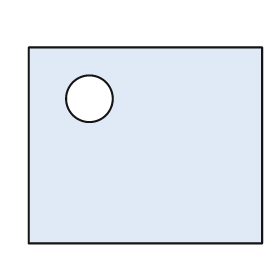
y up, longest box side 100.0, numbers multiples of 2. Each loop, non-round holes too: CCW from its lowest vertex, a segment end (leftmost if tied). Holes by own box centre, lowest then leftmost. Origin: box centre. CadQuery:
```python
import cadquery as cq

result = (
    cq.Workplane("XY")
    .moveTo(-50.0, -42.0)
    .lineTo(50.0, -42.0)
    .lineTo(50.0, 42.0)
    .lineTo(-50.0, 42.0)
    .close()
    .moveTo(-24.0, 20.0)
    .circle(10.0)
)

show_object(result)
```